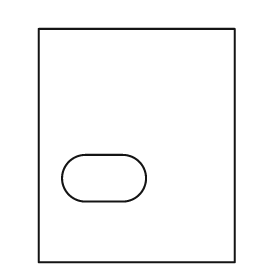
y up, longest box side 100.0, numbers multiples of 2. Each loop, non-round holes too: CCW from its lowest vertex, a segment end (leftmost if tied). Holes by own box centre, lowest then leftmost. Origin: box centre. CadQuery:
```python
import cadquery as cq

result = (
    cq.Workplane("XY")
    .moveTo(-42.0, -50.0)
    .lineTo(42.0, -50.0)
    .lineTo(42.0, 50.0)
    .lineTo(-42.0, 50.0)
    .close()
    .moveTo(-22.0, -24.0)
    .lineTo(-6.0, -24.0)
    .threePointArc((4.0, -14.0), (-6.0, -4.0))
    .lineTo(-22.0, -4.0)
    .threePointArc((-32.0, -14.0), (-22.0, -24.0))
    .close()
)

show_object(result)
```